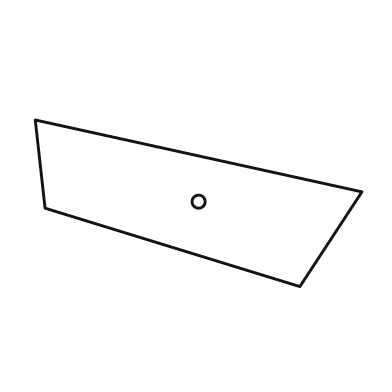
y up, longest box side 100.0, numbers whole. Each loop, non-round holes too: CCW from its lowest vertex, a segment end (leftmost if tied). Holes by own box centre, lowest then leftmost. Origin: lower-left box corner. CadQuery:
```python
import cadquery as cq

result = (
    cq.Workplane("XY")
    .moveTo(81.0, 0.0)
    .lineTo(100.0, 29.0)
    .lineTo(0.0, 51.0)
    .lineTo(3.0, 24.0)
    .close()
    .moveTo(50.0, 26.0)
    .circle(2.0)
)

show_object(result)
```